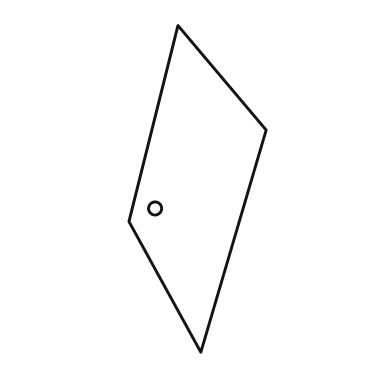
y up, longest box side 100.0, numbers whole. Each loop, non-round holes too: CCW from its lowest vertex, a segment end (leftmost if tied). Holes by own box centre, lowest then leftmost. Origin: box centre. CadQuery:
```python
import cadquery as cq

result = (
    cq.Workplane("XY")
    .moveTo(1.0, -50.0)
    .lineTo(21.0, 18.0)
    .lineTo(-6.0, 50.0)
    .lineTo(-21.0, -10.0)
    .close()
    .moveTo(-13.0, -6.0)
    .circle(2.0)
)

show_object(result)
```